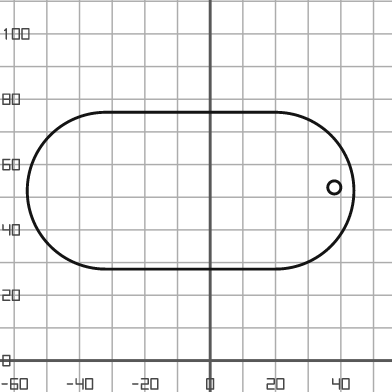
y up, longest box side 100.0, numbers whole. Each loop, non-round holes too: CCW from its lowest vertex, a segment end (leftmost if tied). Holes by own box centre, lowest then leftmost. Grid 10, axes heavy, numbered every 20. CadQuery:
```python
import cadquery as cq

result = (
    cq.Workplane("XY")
    .moveTo(-32.0, 28.0)
    .lineTo(20.0, 28.0)
    .threePointArc((44.0, 52.0), (20.0, 76.0))
    .lineTo(-32.0, 76.0)
    .threePointArc((-56.0, 52.0), (-32.0, 28.0))
    .close()
    .moveTo(38.0, 53.0)
    .circle(2.0)
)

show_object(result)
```